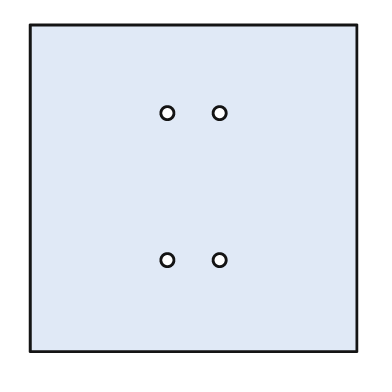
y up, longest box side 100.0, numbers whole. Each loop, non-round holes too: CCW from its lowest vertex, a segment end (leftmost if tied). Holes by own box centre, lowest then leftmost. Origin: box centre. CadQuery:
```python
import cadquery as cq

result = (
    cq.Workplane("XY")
    .moveTo(-50.0, -50.0)
    .lineTo(50.0, -50.0)
    .lineTo(50.0, 50.0)
    .lineTo(-50.0, 50.0)
    .close()
    .moveTo(-8.0, -22.0)
    .circle(2.0)
    .moveTo(8.0, -22.0)
    .circle(2.0)
    .moveTo(-8.0, 23.0)
    .circle(2.0)
    .moveTo(8.0, 23.0)
    .circle(2.0)
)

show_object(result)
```